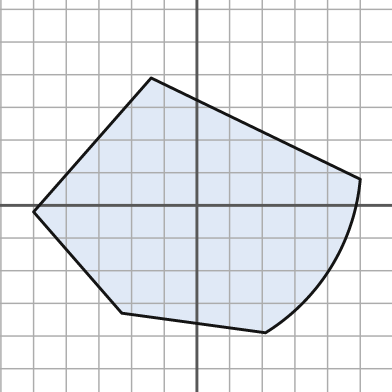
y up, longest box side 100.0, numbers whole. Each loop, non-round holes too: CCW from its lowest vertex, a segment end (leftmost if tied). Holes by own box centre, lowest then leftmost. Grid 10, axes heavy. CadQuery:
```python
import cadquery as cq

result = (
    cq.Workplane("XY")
    .moveTo(21.0, -39.0)
    .threePointArc((41.0, -19.0), (50.0, 8.0))
    .lineTo(-14.0, 39.0)
    .lineTo(-50.0, -2.0)
    .lineTo(-23.0, -33.0)
    .close()
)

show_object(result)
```